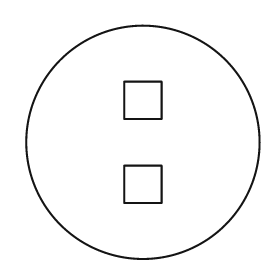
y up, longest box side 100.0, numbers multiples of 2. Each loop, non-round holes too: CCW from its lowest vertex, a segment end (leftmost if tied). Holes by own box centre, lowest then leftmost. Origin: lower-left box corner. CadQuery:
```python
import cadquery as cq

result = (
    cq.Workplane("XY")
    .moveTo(50.0, 50.0)
    .circle(50.0)
    .moveTo(42.0, 24.0)
    .lineTo(58.0, 24.0)
    .lineTo(58.0, 40.0)
    .lineTo(42.0, 40.0)
    .close()
    .moveTo(42.0, 60.0)
    .lineTo(58.0, 60.0)
    .lineTo(58.0, 76.0)
    .lineTo(42.0, 76.0)
    .close()
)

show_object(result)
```